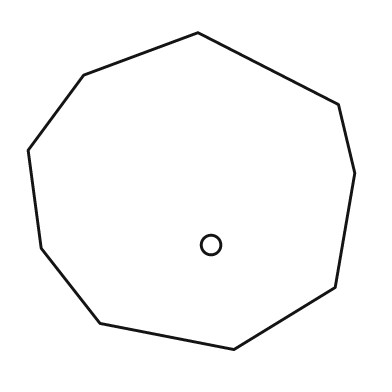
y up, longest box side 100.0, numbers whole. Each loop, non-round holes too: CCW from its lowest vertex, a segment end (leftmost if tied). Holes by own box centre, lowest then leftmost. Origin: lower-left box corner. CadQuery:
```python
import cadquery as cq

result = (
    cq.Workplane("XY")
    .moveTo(63.0, 0.0)
    .lineTo(94.0, 19.0)
    .lineTo(100.0, 54.0)
    .lineTo(95.0, 75.0)
    .lineTo(52.0, 97.0)
    .lineTo(17.0, 84.0)
    .lineTo(0.0, 61.0)
    .lineTo(4.0, 31.0)
    .lineTo(22.0, 8.0)
    .close()
    .moveTo(56.0, 32.0)
    .circle(3.0)
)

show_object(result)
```